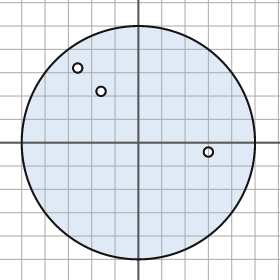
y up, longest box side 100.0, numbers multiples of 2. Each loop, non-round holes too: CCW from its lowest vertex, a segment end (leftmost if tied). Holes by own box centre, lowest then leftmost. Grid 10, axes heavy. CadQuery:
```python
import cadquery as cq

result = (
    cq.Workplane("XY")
    .moveTo(0.0, 0.0)
    .circle(50.0)
    .moveTo(30.0, -4.0)
    .circle(2.0)
    .moveTo(-16.0, 22.0)
    .circle(2.0)
    .moveTo(-26.0, 32.0)
    .circle(2.0)
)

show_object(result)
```